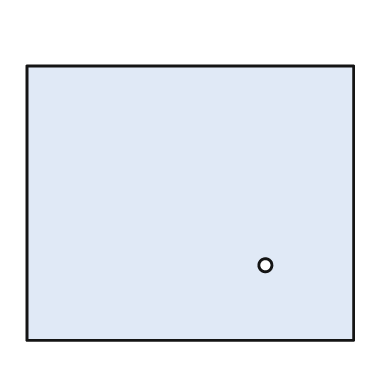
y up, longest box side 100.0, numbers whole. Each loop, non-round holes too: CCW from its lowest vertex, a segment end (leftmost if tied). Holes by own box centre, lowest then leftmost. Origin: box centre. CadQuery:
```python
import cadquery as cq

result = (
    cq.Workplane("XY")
    .moveTo(-50.0, -42.0)
    .lineTo(50.0, -42.0)
    .lineTo(50.0, 42.0)
    .lineTo(-50.0, 42.0)
    .close()
    .moveTo(23.0, -19.0)
    .circle(2.0)
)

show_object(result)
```